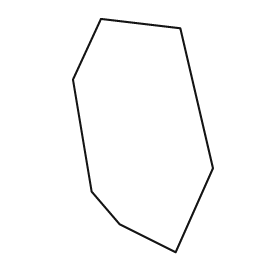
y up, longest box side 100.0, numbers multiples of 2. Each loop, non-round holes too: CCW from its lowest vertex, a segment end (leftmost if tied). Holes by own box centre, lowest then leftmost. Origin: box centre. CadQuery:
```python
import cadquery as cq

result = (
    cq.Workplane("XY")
    .moveTo(14.0, -50.0)
    .lineTo(30.0, -14.0)
    .lineTo(16.0, 46.0)
    .lineTo(-18.0, 50.0)
    .lineTo(-30.0, 24.0)
    .lineTo(-22.0, -24.0)
    .lineTo(-10.0, -38.0)
    .close()
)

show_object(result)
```